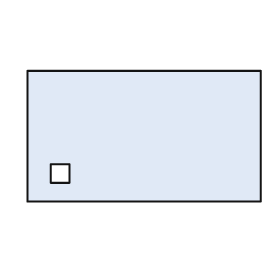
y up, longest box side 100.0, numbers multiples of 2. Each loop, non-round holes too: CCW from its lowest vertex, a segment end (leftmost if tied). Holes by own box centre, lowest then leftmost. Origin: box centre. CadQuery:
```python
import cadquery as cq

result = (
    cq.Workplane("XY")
    .moveTo(-50.0, -28.0)
    .lineTo(50.0, -28.0)
    .lineTo(50.0, 28.0)
    .lineTo(-50.0, 28.0)
    .close()
    .moveTo(-40.0, -20.0)
    .lineTo(-32.0, -20.0)
    .lineTo(-32.0, -12.0)
    .lineTo(-40.0, -12.0)
    .close()
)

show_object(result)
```